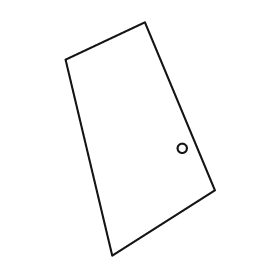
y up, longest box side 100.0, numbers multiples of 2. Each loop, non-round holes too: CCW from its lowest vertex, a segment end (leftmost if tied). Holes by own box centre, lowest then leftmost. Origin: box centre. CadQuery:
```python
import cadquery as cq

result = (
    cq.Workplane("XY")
    .moveTo(-12.0, -50.0)
    .lineTo(32.0, -22.0)
    .lineTo(2.0, 50.0)
    .lineTo(-32.0, 34.0)
    .close()
    .moveTo(18.0, -4.0)
    .circle(2.0)
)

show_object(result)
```